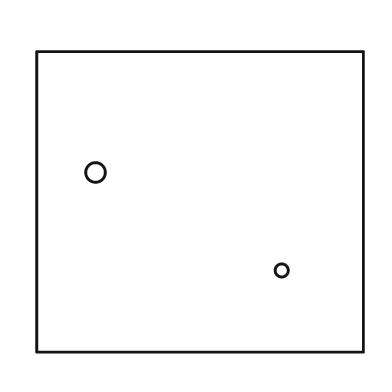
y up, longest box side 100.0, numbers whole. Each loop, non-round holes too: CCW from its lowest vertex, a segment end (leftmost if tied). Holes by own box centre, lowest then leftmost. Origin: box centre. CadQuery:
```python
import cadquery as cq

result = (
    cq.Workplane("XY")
    .moveTo(-50.0, -46.0)
    .lineTo(50.0, -46.0)
    .lineTo(50.0, 46.0)
    .lineTo(-50.0, 46.0)
    .close()
    .moveTo(25.0, -21.0)
    .circle(2.0)
    .moveTo(-32.0, 9.0)
    .circle(3.0)
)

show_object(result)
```